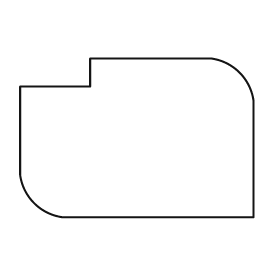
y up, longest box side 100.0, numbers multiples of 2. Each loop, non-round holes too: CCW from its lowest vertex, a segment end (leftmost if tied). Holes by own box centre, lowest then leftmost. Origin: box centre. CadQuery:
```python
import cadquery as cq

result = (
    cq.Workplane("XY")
    .moveTo(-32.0, -34.0)
    .lineTo(50.0, -34.0)
    .lineTo(50.0, 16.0)
    .threePointArc((44.0, 28.0), (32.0, 34.0))
    .lineTo(-20.0, 34.0)
    .lineTo(-20.0, 22.0)
    .lineTo(-50.0, 22.0)
    .lineTo(-50.0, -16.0)
    .threePointArc((-44.0, -28.0), (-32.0, -34.0))
    .close()
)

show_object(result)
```